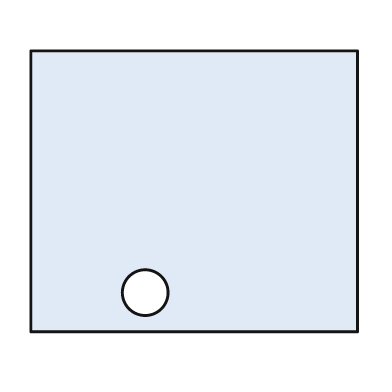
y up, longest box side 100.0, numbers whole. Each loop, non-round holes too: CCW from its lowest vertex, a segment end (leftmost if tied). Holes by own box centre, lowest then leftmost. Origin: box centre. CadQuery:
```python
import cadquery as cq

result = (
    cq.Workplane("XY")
    .moveTo(-50.0, -43.0)
    .lineTo(50.0, -43.0)
    .lineTo(50.0, 43.0)
    .lineTo(-50.0, 43.0)
    .close()
    .moveTo(-15.0, -31.0)
    .circle(7.0)
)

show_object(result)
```